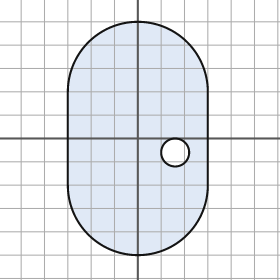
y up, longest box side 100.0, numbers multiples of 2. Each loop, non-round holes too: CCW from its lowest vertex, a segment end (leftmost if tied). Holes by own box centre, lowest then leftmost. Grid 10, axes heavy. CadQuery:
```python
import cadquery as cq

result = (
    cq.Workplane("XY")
    .moveTo(-30.0, -20.0)
    .threePointArc((0.0, -50.0), (30.0, -20.0))
    .lineTo(30.0, 20.0)
    .threePointArc((0.0, 50.0), (-30.0, 20.0))
    .close()
    .moveTo(16.0, -6.0)
    .circle(6.0)
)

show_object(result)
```